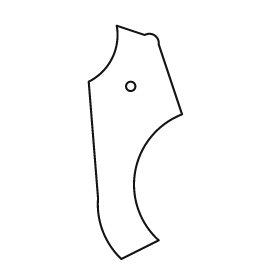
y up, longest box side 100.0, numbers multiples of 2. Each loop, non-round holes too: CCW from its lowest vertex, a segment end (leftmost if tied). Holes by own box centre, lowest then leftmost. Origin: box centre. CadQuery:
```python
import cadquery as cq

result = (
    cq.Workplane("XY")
    .moveTo(-6.0, -50.0)
    .lineTo(10.0, -42.0)
    .threePointArc((0.0, -12.0), (20.0, 12.0))
    .lineTo(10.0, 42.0)
    .threePointArc((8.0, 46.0), (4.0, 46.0))
    .lineTo(-8.0, 50.0)
    .threePointArc((-10.0, 36.0), (-20.0, 26.0))
    .lineTo(-16.0, -24.0)
    .threePointArc((-14.0, -38.0), (-6.0, -50.0))
    .close()
    .moveTo(-2.0, 24.0)
    .circle(2.0)
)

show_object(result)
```